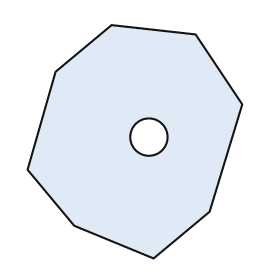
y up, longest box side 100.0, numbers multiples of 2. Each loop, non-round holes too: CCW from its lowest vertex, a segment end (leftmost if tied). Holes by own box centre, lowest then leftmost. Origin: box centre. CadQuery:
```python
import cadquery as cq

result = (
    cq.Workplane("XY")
    .moveTo(8.0, -50.0)
    .lineTo(32.0, -30.0)
    .lineTo(46.0, 16.0)
    .lineTo(26.0, 46.0)
    .lineTo(-10.0, 50.0)
    .lineTo(-34.0, 30.0)
    .lineTo(-46.0, -12.0)
    .lineTo(-26.0, -36.0)
    .close()
    .moveTo(6.0, 2.0)
    .circle(8.0)
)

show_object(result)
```